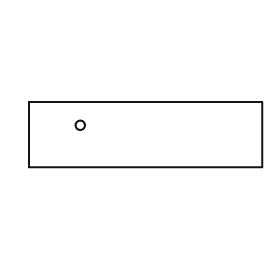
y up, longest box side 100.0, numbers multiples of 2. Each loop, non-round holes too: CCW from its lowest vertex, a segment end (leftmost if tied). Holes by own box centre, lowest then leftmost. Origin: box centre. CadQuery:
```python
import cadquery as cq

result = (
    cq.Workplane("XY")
    .moveTo(-50.0, -14.0)
    .lineTo(50.0, -14.0)
    .lineTo(50.0, 14.0)
    .lineTo(-50.0, 14.0)
    .close()
    .moveTo(-28.0, 4.0)
    .circle(2.0)
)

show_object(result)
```